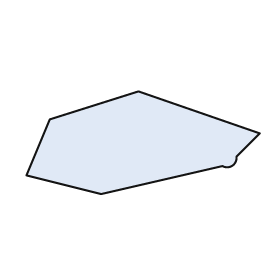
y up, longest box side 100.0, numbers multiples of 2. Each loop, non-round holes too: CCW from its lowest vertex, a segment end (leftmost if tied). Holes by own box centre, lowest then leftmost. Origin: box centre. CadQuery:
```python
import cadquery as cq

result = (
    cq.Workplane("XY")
    .moveTo(-18.0, -22.0)
    .lineTo(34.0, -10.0)
    .threePointArc((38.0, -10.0), (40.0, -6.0))
    .lineTo(50.0, 4.0)
    .lineTo(-2.0, 22.0)
    .lineTo(-40.0, 10.0)
    .lineTo(-50.0, -14.0)
    .close()
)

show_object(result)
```